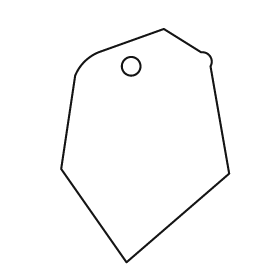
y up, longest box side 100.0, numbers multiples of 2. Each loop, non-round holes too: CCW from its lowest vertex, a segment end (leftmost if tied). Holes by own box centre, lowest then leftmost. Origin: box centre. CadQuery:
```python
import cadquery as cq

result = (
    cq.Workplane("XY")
    .moveTo(-8.0, -50.0)
    .lineTo(36.0, -12.0)
    .lineTo(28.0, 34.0)
    .threePointArc((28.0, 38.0), (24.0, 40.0))
    .lineTo(8.0, 50.0)
    .lineTo(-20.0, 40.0)
    .threePointArc((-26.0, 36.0), (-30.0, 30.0))
    .lineTo(-36.0, -10.0)
    .close()
    .moveTo(-6.0, 34.0)
    .circle(4.0)
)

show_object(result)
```